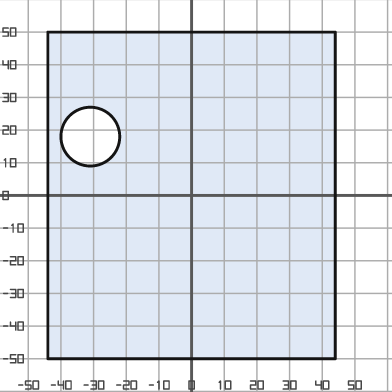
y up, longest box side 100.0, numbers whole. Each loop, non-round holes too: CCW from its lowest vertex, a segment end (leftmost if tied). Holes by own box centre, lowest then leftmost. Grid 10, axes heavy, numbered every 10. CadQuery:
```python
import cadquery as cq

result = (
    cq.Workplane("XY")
    .moveTo(-44.0, -50.0)
    .lineTo(44.0, -50.0)
    .lineTo(44.0, 50.0)
    .lineTo(-44.0, 50.0)
    .close()
    .moveTo(-31.0, 18.0)
    .circle(9.0)
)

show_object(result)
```